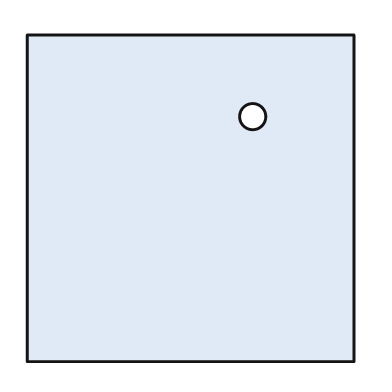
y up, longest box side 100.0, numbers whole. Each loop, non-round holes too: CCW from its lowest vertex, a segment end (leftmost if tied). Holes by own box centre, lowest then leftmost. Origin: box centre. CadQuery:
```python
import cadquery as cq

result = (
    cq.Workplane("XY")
    .moveTo(-50.0, -50.0)
    .lineTo(50.0, -50.0)
    .lineTo(50.0, 50.0)
    .lineTo(-50.0, 50.0)
    .close()
    .moveTo(19.0, 25.0)
    .circle(4.0)
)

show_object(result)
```